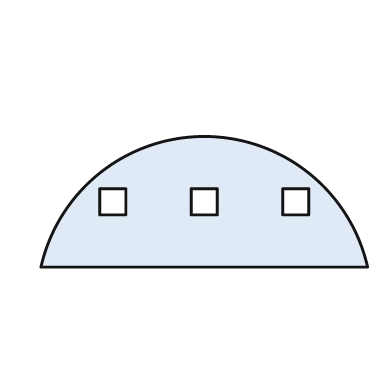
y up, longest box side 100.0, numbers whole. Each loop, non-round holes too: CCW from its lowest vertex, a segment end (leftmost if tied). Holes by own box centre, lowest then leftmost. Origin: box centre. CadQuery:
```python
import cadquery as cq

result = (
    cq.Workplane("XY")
    .moveTo(-50.0, -20.0)
    .lineTo(50.0, -20.0)
    .threePointArc((0.0, 20.0), (-50.0, -20.0))
    .close()
    .moveTo(-32.0, -4.0)
    .lineTo(-24.0, -4.0)
    .lineTo(-24.0, 4.0)
    .lineTo(-32.0, 4.0)
    .close()
    .moveTo(-4.0, -4.0)
    .lineTo(4.0, -4.0)
    .lineTo(4.0, 4.0)
    .lineTo(-4.0, 4.0)
    .close()
    .moveTo(24.0, -4.0)
    .lineTo(32.0, -4.0)
    .lineTo(32.0, 4.0)
    .lineTo(24.0, 4.0)
    .close()
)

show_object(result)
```